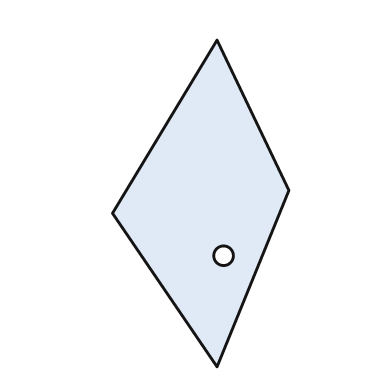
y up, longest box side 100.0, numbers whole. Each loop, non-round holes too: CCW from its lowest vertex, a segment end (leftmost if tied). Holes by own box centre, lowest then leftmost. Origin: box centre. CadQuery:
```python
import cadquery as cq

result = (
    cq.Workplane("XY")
    .moveTo(5.0, -50.0)
    .lineTo(27.0, 4.0)
    .lineTo(5.0, 50.0)
    .lineTo(-27.0, -3.0)
    .close()
    .moveTo(7.0, -16.0)
    .circle(3.0)
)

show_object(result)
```